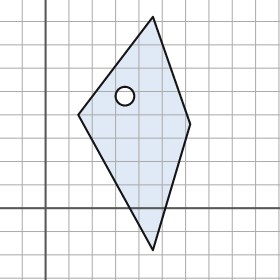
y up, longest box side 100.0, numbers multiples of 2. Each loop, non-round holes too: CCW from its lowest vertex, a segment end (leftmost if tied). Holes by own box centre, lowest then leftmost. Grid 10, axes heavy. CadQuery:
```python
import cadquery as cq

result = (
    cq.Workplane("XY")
    .moveTo(46.0, -18.0)
    .lineTo(62.0, 36.0)
    .lineTo(46.0, 82.0)
    .lineTo(14.0, 40.0)
    .close()
    .moveTo(34.0, 48.0)
    .circle(4.0)
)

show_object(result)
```